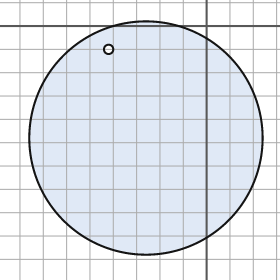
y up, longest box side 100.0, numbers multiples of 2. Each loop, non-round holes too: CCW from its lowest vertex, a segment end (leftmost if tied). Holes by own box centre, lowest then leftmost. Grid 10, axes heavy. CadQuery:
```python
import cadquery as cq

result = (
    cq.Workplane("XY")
    .moveTo(-26.0, -48.0)
    .circle(50.0)
    .moveTo(-42.0, -10.0)
    .circle(2.0)
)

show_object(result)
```